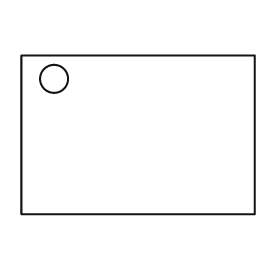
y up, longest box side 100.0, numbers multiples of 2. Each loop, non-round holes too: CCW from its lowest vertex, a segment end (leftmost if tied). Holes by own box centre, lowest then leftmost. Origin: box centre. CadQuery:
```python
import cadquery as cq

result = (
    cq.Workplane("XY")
    .moveTo(-50.0, -34.0)
    .lineTo(50.0, -34.0)
    .lineTo(50.0, 34.0)
    .lineTo(-50.0, 34.0)
    .close()
    .moveTo(-36.0, 24.0)
    .circle(6.0)
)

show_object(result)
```